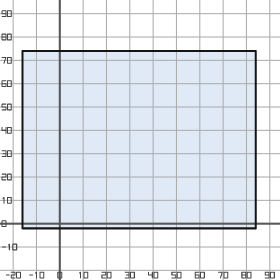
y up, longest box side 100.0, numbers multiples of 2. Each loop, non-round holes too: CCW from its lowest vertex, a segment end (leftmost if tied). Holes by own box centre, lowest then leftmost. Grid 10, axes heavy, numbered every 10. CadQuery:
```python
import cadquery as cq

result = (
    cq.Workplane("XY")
    .moveTo(-16.0, -2.0)
    .lineTo(84.0, -2.0)
    .lineTo(84.0, 74.0)
    .lineTo(-16.0, 74.0)
    .close()
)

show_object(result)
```